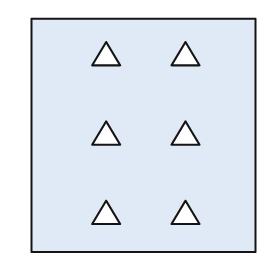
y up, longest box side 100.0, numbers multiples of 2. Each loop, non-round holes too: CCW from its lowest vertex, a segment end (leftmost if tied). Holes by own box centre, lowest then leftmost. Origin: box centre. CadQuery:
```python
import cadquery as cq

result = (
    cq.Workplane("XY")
    .moveTo(-48.0, -50.0)
    .lineTo(48.0, -50.0)
    .lineTo(48.0, 50.0)
    .lineTo(-48.0, 50.0)
    .close()
    .moveTo(-22.0, -38.0)
    .lineTo(-10.0, -38.0)
    .lineTo(-16.0, -28.0)
    .close()
    .moveTo(12.0, -38.0)
    .lineTo(24.0, -38.0)
    .lineTo(18.0, -28.0)
    .close()
    .moveTo(-22.0, -4.0)
    .lineTo(-10.0, -4.0)
    .lineTo(-16.0, 6.0)
    .close()
    .moveTo(12.0, -4.0)
    .lineTo(24.0, -4.0)
    .lineTo(18.0, 6.0)
    .close()
    .moveTo(-22.0, 30.0)
    .lineTo(-10.0, 30.0)
    .lineTo(-16.0, 40.0)
    .close()
    .moveTo(12.0, 30.0)
    .lineTo(24.0, 30.0)
    .lineTo(18.0, 40.0)
    .close()
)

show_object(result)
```